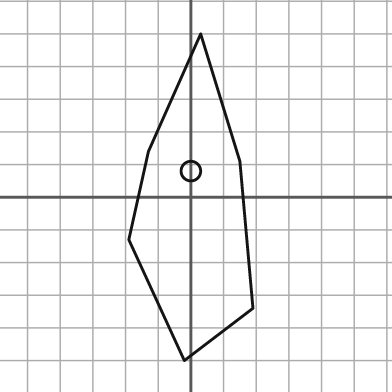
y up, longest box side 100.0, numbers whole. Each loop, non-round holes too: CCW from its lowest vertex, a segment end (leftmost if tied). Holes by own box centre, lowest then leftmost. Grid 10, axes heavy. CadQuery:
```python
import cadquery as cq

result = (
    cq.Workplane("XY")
    .moveTo(-2.0, -50.0)
    .lineTo(19.0, -34.0)
    .lineTo(15.0, 11.0)
    .lineTo(3.0, 50.0)
    .lineTo(-13.0, 14.0)
    .lineTo(-19.0, -13.0)
    .close()
    .moveTo(0.0, 8.0)
    .circle(3.0)
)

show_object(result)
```